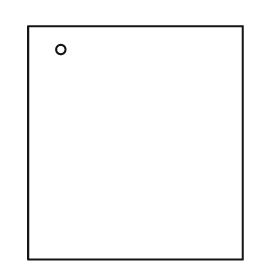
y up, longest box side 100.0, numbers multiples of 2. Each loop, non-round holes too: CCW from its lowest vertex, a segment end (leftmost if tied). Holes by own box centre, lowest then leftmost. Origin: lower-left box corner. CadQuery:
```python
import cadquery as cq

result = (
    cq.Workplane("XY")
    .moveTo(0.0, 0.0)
    .lineTo(92.0, 0.0)
    .lineTo(92.0, 100.0)
    .lineTo(0.0, 100.0)
    .close()
    .moveTo(14.0, 90.0)
    .circle(2.0)
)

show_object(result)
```